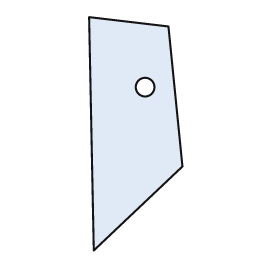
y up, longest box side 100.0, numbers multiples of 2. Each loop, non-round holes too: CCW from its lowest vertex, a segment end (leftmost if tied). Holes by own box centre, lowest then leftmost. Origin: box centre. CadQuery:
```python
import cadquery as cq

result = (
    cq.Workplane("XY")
    .moveTo(-18.0, -50.0)
    .lineTo(20.0, -14.0)
    .lineTo(14.0, 46.0)
    .lineTo(-20.0, 50.0)
    .close()
    .moveTo(4.0, 20.0)
    .circle(4.0)
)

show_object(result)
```